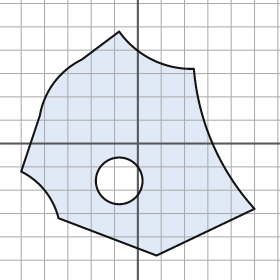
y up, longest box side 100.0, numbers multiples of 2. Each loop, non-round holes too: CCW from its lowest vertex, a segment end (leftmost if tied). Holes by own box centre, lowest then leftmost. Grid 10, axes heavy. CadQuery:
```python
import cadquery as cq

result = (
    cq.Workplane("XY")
    .moveTo(8.0, -48.0)
    .lineTo(50.0, -28.0)
    .threePointArc((32.0, 0.0), (24.0, 32.0))
    .threePointArc((6.0, 36.0), (-8.0, 48.0))
    .lineTo(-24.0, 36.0)
    .threePointArc((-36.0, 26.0), (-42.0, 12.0))
    .lineTo(-50.0, -12.0)
    .threePointArc((-40.0, -20.0), (-34.0, -32.0))
    .close()
    .moveTo(-8.0, -16.0)
    .circle(10.0)
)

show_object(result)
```